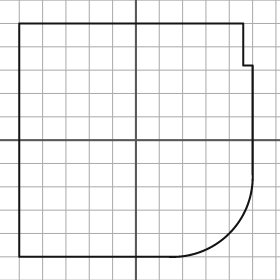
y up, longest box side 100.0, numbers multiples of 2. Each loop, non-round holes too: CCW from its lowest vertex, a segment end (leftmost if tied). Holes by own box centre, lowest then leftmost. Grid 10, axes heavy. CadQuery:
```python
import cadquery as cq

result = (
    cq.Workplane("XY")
    .moveTo(-50.0, -50.0)
    .lineTo(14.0, -50.0)
    .threePointArc((40.0, -40.0), (50.0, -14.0))
    .lineTo(50.0, 32.0)
    .lineTo(46.0, 32.0)
    .lineTo(46.0, 50.0)
    .lineTo(-50.0, 50.0)
    .close()
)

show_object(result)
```